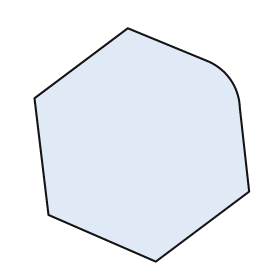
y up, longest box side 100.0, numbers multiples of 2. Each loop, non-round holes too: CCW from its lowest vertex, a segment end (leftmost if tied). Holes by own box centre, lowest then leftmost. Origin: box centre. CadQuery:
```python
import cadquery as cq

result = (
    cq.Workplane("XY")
    .moveTo(6.0, -50.0)
    .lineTo(46.0, -20.0)
    .lineTo(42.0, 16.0)
    .threePointArc((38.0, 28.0), (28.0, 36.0))
    .lineTo(-6.0, 50.0)
    .lineTo(-46.0, 20.0)
    .lineTo(-40.0, -30.0)
    .close()
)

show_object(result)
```